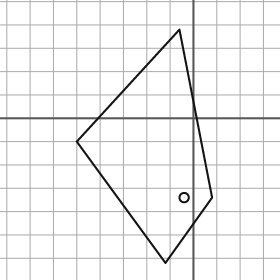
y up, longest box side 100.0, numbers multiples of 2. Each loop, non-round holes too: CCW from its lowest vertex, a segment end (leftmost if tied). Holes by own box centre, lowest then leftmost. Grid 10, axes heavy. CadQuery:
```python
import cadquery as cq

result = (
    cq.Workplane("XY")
    .moveTo(-12.0, -62.0)
    .lineTo(8.0, -34.0)
    .lineTo(-6.0, 38.0)
    .lineTo(-50.0, -10.0)
    .close()
    .moveTo(-4.0, -34.0)
    .circle(2.0)
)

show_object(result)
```